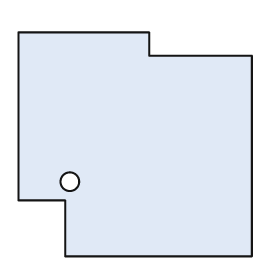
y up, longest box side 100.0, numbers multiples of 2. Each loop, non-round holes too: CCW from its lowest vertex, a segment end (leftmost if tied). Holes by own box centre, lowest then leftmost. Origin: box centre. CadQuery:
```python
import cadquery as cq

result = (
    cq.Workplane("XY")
    .moveTo(-30.0, -48.0)
    .lineTo(50.0, -48.0)
    .lineTo(50.0, 38.0)
    .lineTo(6.0, 38.0)
    .lineTo(6.0, 48.0)
    .lineTo(-50.0, 48.0)
    .lineTo(-50.0, -24.0)
    .lineTo(-30.0, -24.0)
    .close()
    .moveTo(-28.0, -16.0)
    .circle(4.0)
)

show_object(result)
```